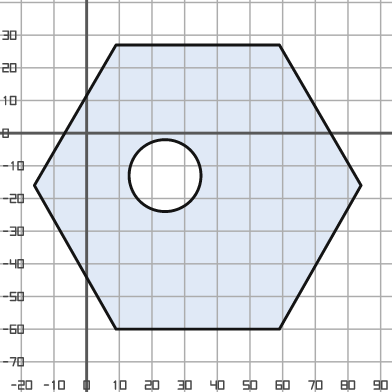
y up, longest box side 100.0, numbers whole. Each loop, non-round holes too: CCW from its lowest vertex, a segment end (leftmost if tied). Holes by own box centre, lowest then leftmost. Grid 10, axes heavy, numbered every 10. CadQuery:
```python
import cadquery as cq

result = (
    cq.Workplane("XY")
    .moveTo(9.0, -60.0)
    .lineTo(59.0, -60.0)
    .lineTo(84.0, -16.0)
    .lineTo(59.0, 27.0)
    .lineTo(9.0, 27.0)
    .lineTo(-16.0, -16.0)
    .close()
    .moveTo(24.0, -13.0)
    .circle(11.0)
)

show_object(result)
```